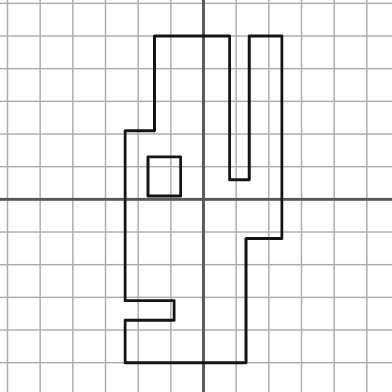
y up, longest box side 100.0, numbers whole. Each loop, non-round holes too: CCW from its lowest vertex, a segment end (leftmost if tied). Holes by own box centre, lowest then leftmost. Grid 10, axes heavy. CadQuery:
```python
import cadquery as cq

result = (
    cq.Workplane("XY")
    .moveTo(-24.0, -50.0)
    .lineTo(13.0, -50.0)
    .lineTo(13.0, -12.0)
    .lineTo(24.0, -12.0)
    .lineTo(24.0, 50.0)
    .lineTo(14.0, 50.0)
    .lineTo(14.0, 6.0)
    .lineTo(8.0, 6.0)
    .lineTo(8.0, 50.0)
    .lineTo(-15.0, 50.0)
    .lineTo(-15.0, 21.0)
    .lineTo(-24.0, 21.0)
    .lineTo(-24.0, -31.0)
    .lineTo(-9.0, -31.0)
    .lineTo(-9.0, -37.0)
    .lineTo(-24.0, -37.0)
    .close()
    .moveTo(-17.0, 1.0)
    .lineTo(-7.0, 1.0)
    .lineTo(-7.0, 13.0)
    .lineTo(-17.0, 13.0)
    .close()
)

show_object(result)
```